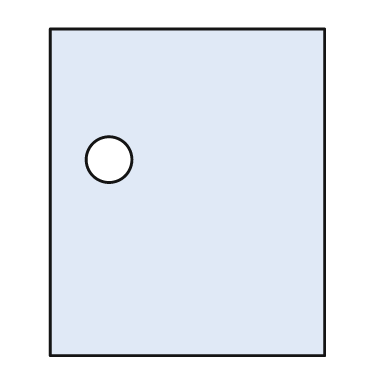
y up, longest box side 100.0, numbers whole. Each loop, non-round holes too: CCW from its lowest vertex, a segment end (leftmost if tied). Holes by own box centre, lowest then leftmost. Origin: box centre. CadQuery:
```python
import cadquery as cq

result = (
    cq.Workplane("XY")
    .moveTo(-42.0, -50.0)
    .lineTo(42.0, -50.0)
    .lineTo(42.0, 50.0)
    .lineTo(-42.0, 50.0)
    .close()
    .moveTo(-24.0, 10.0)
    .circle(7.0)
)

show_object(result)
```